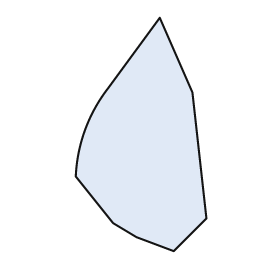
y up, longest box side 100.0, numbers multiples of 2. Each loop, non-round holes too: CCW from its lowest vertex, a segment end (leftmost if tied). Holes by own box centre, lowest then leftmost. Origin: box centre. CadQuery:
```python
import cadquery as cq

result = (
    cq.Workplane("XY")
    .moveTo(14.0, -50.0)
    .lineTo(28.0, -36.0)
    .lineTo(22.0, 18.0)
    .lineTo(8.0, 50.0)
    .lineTo(-14.0, 20.0)
    .threePointArc((-24.0, 2.0), (-28.0, -18.0))
    .lineTo(-12.0, -38.0)
    .lineTo(-2.0, -44.0)
    .close()
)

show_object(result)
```